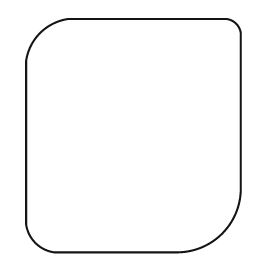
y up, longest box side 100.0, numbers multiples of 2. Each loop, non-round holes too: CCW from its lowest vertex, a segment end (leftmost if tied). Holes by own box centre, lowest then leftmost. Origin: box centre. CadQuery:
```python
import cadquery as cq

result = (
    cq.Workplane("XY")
    .moveTo(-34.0, -50.0)
    .lineTo(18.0, -50.0)
    .threePointArc((38.0, -42.0), (46.0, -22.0))
    .lineTo(46.0, 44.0)
    .threePointArc((44.0, 48.0), (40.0, 50.0))
    .lineTo(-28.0, 50.0)
    .threePointArc((-40.0, 44.0), (-46.0, 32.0))
    .lineTo(-46.0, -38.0)
    .threePointArc((-42.0, -46.0), (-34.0, -50.0))
    .close()
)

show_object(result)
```